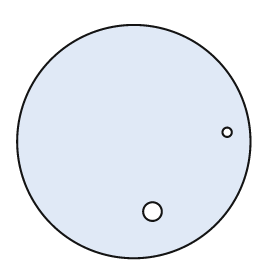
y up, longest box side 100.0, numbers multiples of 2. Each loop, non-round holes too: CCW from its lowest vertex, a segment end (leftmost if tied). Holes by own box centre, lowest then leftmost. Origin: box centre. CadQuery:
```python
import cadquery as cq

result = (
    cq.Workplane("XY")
    .moveTo(0.0, 0.0)
    .circle(50.0)
    .moveTo(8.0, -30.0)
    .circle(4.0)
    .moveTo(40.0, 4.0)
    .circle(2.0)
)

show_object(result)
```